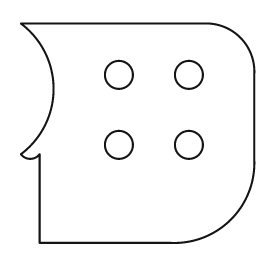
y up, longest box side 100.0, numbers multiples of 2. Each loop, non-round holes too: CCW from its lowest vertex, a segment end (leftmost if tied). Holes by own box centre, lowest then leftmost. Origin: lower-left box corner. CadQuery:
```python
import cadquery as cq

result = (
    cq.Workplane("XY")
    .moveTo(8.0, 0.0)
    .lineTo(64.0, 0.0)
    .threePointArc((90.0, 10.0), (100.0, 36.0))
    .lineTo(100.0, 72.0)
    .threePointArc((94.0, 88.0), (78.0, 94.0))
    .lineTo(0.0, 94.0)
    .threePointArc((14.0, 66.0), (0.0, 38.0))
    .threePointArc((4.0, 36.0), (8.0, 38.0))
    .close()
    .moveTo(42.0, 42.0)
    .circle(6.0)
    .moveTo(72.0, 42.0)
    .circle(6.0)
    .moveTo(42.0, 72.0)
    .circle(6.0)
    .moveTo(72.0, 72.0)
    .circle(6.0)
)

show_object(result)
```